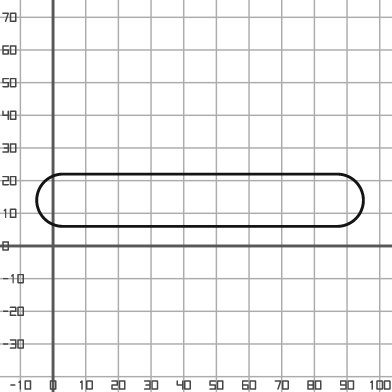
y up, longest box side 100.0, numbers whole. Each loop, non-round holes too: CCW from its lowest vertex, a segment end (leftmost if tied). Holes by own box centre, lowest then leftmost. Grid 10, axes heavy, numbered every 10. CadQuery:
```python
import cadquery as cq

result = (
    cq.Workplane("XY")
    .moveTo(3.0, 6.0)
    .lineTo(87.0, 6.0)
    .threePointArc((95.0, 14.0), (87.0, 22.0))
    .lineTo(3.0, 22.0)
    .threePointArc((-5.0, 14.0), (3.0, 6.0))
    .close()
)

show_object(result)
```